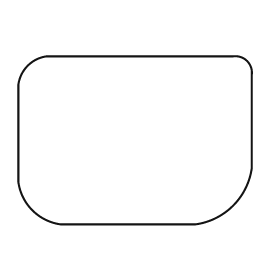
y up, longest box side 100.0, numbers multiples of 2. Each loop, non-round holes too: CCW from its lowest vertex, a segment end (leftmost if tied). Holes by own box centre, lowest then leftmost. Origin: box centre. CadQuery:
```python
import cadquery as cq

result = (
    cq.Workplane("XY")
    .moveTo(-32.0, -36.0)
    .lineTo(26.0, -36.0)
    .threePointArc((42.0, -28.0), (50.0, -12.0))
    .lineTo(50.0, 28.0)
    .threePointArc((48.0, 34.0), (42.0, 36.0))
    .lineTo(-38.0, 36.0)
    .threePointArc((-46.0, 32.0), (-50.0, 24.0))
    .lineTo(-50.0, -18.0)
    .threePointArc((-44.0, -30.0), (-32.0, -36.0))
    .close()
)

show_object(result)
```